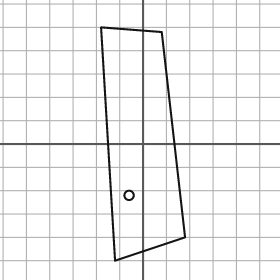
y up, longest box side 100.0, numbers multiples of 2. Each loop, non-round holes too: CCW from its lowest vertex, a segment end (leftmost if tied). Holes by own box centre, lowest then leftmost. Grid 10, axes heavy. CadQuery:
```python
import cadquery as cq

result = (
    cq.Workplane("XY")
    .moveTo(-12.0, -50.0)
    .lineTo(18.0, -40.0)
    .lineTo(8.0, 48.0)
    .lineTo(-18.0, 50.0)
    .close()
    .moveTo(-6.0, -22.0)
    .circle(2.0)
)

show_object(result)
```